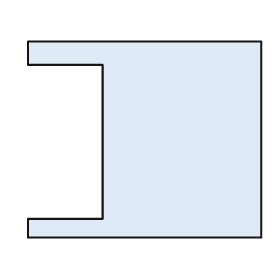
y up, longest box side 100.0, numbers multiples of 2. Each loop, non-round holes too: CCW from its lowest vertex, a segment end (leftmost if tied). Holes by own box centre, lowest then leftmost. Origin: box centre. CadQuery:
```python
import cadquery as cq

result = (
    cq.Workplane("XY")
    .moveTo(-50.0, -42.0)
    .lineTo(50.0, -42.0)
    .lineTo(50.0, 42.0)
    .lineTo(-50.0, 42.0)
    .lineTo(-50.0, 32.0)
    .lineTo(-18.0, 32.0)
    .lineTo(-18.0, -34.0)
    .lineTo(-50.0, -34.0)
    .close()
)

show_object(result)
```